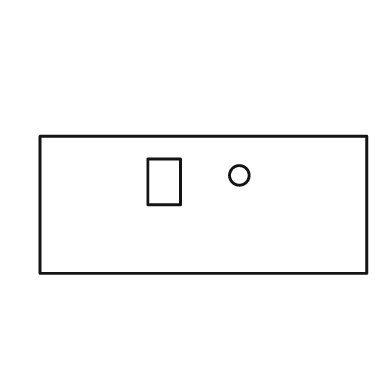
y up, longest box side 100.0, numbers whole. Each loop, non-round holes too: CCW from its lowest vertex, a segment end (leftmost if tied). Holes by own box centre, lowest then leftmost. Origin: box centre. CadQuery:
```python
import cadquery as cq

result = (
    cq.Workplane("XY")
    .moveTo(-50.0, -21.0)
    .lineTo(50.0, -21.0)
    .lineTo(50.0, 21.0)
    .lineTo(-50.0, 21.0)
    .close()
    .moveTo(-17.0, 0.0)
    .lineTo(-7.0, 0.0)
    .lineTo(-7.0, 14.0)
    .lineTo(-17.0, 14.0)
    .close()
    .moveTo(11.0, 9.0)
    .circle(3.0)
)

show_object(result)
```